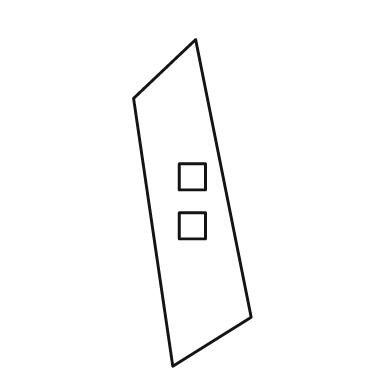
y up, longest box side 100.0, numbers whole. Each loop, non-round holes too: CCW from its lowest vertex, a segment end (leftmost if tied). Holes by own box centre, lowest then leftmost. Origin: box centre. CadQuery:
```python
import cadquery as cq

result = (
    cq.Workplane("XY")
    .moveTo(-6.0, -50.0)
    .lineTo(18.0, -35.0)
    .lineTo(1.0, 50.0)
    .lineTo(-18.0, 32.0)
    .close()
    .moveTo(-4.0, -11.0)
    .lineTo(4.0, -11.0)
    .lineTo(4.0, -3.0)
    .lineTo(-4.0, -3.0)
    .close()
    .moveTo(-4.0, 4.0)
    .lineTo(4.0, 4.0)
    .lineTo(4.0, 12.0)
    .lineTo(-4.0, 12.0)
    .close()
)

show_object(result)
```